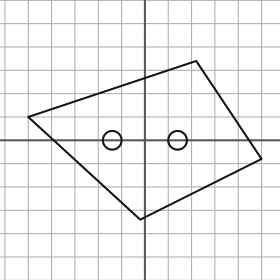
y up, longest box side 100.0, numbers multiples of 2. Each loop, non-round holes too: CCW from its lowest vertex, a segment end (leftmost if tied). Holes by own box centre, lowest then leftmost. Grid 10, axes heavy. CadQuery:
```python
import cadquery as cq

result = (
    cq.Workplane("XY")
    .moveTo(-2.0, -34.0)
    .lineTo(50.0, -8.0)
    .lineTo(22.0, 34.0)
    .lineTo(-50.0, 10.0)
    .close()
    .moveTo(-14.0, 0.0)
    .circle(4.0)
    .moveTo(14.0, 0.0)
    .circle(4.0)
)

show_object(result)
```